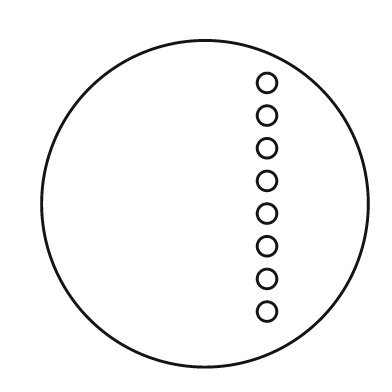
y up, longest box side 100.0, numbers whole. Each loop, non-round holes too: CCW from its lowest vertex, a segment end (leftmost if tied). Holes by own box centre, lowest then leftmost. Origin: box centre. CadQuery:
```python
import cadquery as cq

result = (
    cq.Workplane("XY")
    .moveTo(0.0, 0.0)
    .circle(50.0)
    .moveTo(19.0, -33.0)
    .circle(3.0)
    .moveTo(19.0, -23.0)
    .circle(3.0)
    .moveTo(19.0, -13.0)
    .circle(3.0)
    .moveTo(19.0, -3.0)
    .circle(3.0)
    .moveTo(19.0, 7.0)
    .circle(3.0)
    .moveTo(19.0, 17.0)
    .circle(3.0)
    .moveTo(19.0, 27.0)
    .circle(3.0)
    .moveTo(19.0, 37.0)
    .circle(3.0)
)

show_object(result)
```